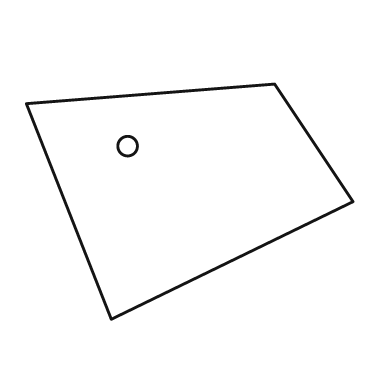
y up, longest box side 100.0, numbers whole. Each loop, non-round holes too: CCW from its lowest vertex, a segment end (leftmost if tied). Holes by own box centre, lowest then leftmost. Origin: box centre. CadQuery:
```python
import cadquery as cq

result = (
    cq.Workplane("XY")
    .moveTo(-24.0, -36.0)
    .lineTo(50.0, 0.0)
    .lineTo(26.0, 36.0)
    .lineTo(-50.0, 30.0)
    .close()
    .moveTo(-19.0, 17.0)
    .circle(3.0)
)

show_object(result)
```